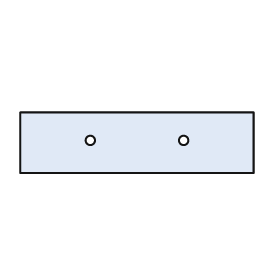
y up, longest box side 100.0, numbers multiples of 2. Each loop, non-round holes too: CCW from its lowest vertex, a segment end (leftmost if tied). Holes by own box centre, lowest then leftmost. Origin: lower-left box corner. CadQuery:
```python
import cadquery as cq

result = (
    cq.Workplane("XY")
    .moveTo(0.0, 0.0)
    .lineTo(100.0, 0.0)
    .lineTo(100.0, 26.0)
    .lineTo(0.0, 26.0)
    .close()
    .moveTo(30.0, 14.0)
    .circle(2.0)
    .moveTo(70.0, 14.0)
    .circle(2.0)
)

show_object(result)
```